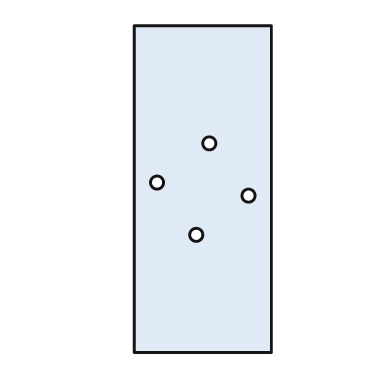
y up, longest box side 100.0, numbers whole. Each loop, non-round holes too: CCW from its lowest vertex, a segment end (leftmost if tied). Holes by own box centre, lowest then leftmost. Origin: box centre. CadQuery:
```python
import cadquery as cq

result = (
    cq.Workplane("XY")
    .moveTo(-21.0, -50.0)
    .lineTo(21.0, -50.0)
    .lineTo(21.0, 50.0)
    .lineTo(-21.0, 50.0)
    .close()
    .moveTo(-2.0, -14.0)
    .circle(2.0)
    .moveTo(14.0, -2.0)
    .circle(2.0)
    .moveTo(-14.0, 2.0)
    .circle(2.0)
    .moveTo(2.0, 14.0)
    .circle(2.0)
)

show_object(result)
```